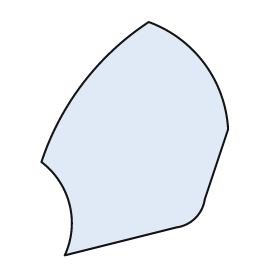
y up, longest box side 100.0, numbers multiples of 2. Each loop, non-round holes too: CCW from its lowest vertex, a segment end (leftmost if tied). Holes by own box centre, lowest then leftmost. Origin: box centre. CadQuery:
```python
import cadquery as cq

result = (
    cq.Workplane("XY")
    .moveTo(-30.0, -50.0)
    .lineTo(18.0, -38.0)
    .threePointArc((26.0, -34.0), (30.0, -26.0))
    .lineTo(40.0, 4.0)
    .threePointArc((30.0, 32.0), (6.0, 50.0))
    .threePointArc((-22.0, 24.0), (-40.0, -10.0))
    .threePointArc((-28.0, -28.0), (-30.0, -50.0))
    .close()
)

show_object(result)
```